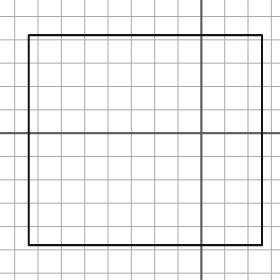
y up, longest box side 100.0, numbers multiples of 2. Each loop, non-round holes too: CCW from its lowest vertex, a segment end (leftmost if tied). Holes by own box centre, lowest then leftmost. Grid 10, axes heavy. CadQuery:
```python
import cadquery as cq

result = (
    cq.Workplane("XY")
    .moveTo(-74.0, -48.0)
    .lineTo(26.0, -48.0)
    .lineTo(26.0, 42.0)
    .lineTo(-74.0, 42.0)
    .close()
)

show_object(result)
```